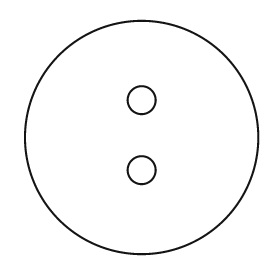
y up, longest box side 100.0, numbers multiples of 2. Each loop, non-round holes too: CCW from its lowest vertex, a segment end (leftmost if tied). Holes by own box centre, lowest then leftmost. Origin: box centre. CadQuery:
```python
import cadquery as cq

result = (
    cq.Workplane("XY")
    .moveTo(0.0, 0.0)
    .circle(50.0)
    .moveTo(0.0, -14.0)
    .circle(6.0)
    .moveTo(0.0, 16.0)
    .circle(6.0)
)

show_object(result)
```